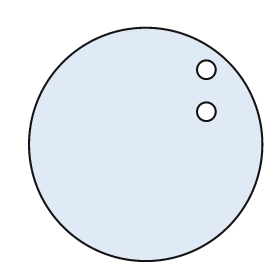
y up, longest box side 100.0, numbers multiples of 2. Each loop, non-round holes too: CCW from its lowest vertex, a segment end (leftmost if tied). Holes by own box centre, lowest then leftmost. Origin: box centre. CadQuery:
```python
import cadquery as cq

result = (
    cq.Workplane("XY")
    .moveTo(0.0, 0.0)
    .circle(50.0)
    .moveTo(26.0, 14.0)
    .circle(4.0)
    .moveTo(26.0, 32.0)
    .circle(4.0)
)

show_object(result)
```